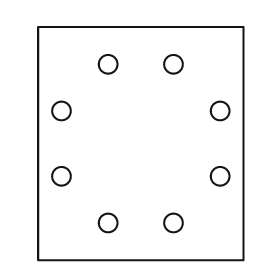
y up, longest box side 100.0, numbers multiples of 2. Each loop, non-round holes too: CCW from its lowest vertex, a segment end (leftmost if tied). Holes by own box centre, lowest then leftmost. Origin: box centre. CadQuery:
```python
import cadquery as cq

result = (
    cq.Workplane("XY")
    .moveTo(-44.0, -50.0)
    .lineTo(44.0, -50.0)
    .lineTo(44.0, 50.0)
    .lineTo(-44.0, 50.0)
    .close()
    .moveTo(-14.0, -34.0)
    .circle(4.0)
    .moveTo(14.0, -34.0)
    .circle(4.0)
    .moveTo(-34.0, -14.0)
    .circle(4.0)
    .moveTo(34.0, -14.0)
    .circle(4.0)
    .moveTo(-34.0, 14.0)
    .circle(4.0)
    .moveTo(34.0, 14.0)
    .circle(4.0)
    .moveTo(-14.0, 34.0)
    .circle(4.0)
    .moveTo(14.0, 34.0)
    .circle(4.0)
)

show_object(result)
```